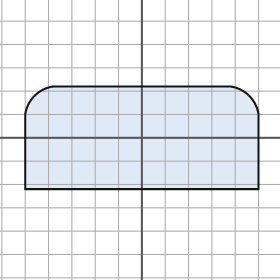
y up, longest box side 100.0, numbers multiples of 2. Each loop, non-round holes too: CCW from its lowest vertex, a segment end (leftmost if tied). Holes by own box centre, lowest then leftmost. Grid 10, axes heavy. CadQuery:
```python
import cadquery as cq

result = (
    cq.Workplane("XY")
    .moveTo(-50.0, -22.0)
    .lineTo(50.0, -22.0)
    .lineTo(50.0, 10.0)
    .threePointArc((46.0, 18.0), (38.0, 22.0))
    .lineTo(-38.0, 22.0)
    .threePointArc((-46.0, 18.0), (-50.0, 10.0))
    .close()
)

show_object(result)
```